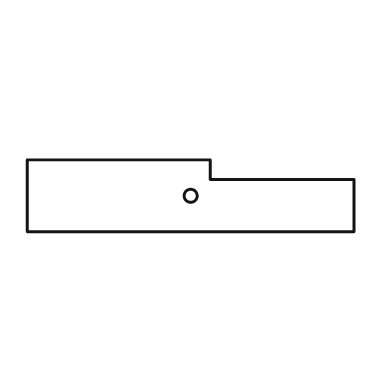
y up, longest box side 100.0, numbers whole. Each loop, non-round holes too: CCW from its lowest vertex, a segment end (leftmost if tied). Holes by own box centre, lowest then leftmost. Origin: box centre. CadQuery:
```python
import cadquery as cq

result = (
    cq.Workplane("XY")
    .moveTo(-50.0, -11.0)
    .lineTo(50.0, -11.0)
    .lineTo(50.0, 5.0)
    .lineTo(6.0, 5.0)
    .lineTo(6.0, 11.0)
    .lineTo(-50.0, 11.0)
    .close()
    .moveTo(0.0, 0.0)
    .circle(2.0)
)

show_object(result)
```